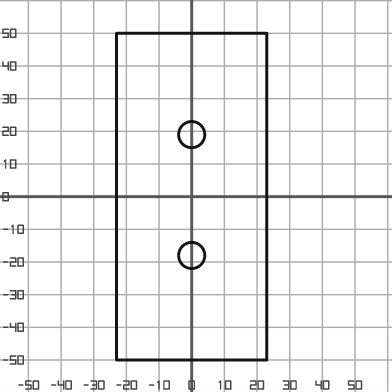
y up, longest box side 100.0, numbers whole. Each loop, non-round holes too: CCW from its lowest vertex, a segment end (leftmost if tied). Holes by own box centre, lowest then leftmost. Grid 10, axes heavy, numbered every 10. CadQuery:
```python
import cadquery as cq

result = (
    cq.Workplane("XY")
    .moveTo(-23.0, -50.0)
    .lineTo(23.0, -50.0)
    .lineTo(23.0, 50.0)
    .lineTo(-23.0, 50.0)
    .close()
    .moveTo(0.0, -18.0)
    .circle(4.0)
    .moveTo(0.0, 19.0)
    .circle(4.0)
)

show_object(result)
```